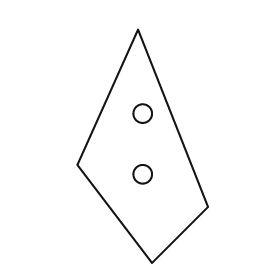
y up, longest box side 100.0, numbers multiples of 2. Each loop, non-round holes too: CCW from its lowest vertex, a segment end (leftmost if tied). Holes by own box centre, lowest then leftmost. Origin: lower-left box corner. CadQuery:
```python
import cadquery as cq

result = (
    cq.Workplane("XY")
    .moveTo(32.0, 0.0)
    .lineTo(56.0, 24.0)
    .lineTo(26.0, 100.0)
    .lineTo(0.0, 42.0)
    .close()
    .moveTo(28.0, 38.0)
    .circle(4.0)
    .moveTo(28.0, 64.0)
    .circle(4.0)
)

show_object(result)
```